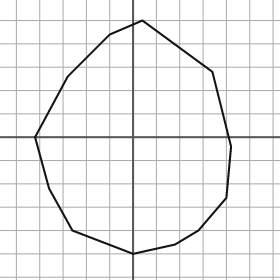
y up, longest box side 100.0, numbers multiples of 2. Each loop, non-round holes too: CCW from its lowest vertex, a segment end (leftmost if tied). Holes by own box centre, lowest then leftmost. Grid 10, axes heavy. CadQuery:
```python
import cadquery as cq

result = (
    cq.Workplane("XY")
    .moveTo(0.0, -50.0)
    .lineTo(18.0, -46.0)
    .lineTo(28.0, -40.0)
    .lineTo(40.0, -26.0)
    .lineTo(42.0, -4.0)
    .lineTo(34.0, 28.0)
    .lineTo(4.0, 50.0)
    .lineTo(-10.0, 44.0)
    .lineTo(-28.0, 26.0)
    .lineTo(-42.0, 0.0)
    .lineTo(-36.0, -22.0)
    .lineTo(-26.0, -40.0)
    .close()
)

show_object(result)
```